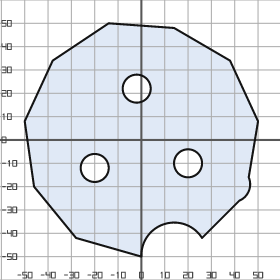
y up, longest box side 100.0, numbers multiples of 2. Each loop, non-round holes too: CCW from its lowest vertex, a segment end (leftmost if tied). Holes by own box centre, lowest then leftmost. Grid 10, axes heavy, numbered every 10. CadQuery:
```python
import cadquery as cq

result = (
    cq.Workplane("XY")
    .moveTo(0.0, -50.0)
    .threePointArc((10.0, -36.0), (26.0, -42.0))
    .lineTo(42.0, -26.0)
    .threePointArc((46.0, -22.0), (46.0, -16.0))
    .lineTo(50.0, 8.0)
    .lineTo(38.0, 34.0)
    .lineTo(14.0, 48.0)
    .lineTo(-14.0, 50.0)
    .lineTo(-38.0, 34.0)
    .lineTo(-50.0, 8.0)
    .lineTo(-46.0, -20.0)
    .lineTo(-28.0, -42.0)
    .close()
    .moveTo(-20.0, -12.0)
    .circle(6.0)
    .moveTo(20.0, -10.0)
    .circle(6.0)
    .moveTo(-2.0, 22.0)
    .circle(6.0)
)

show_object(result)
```